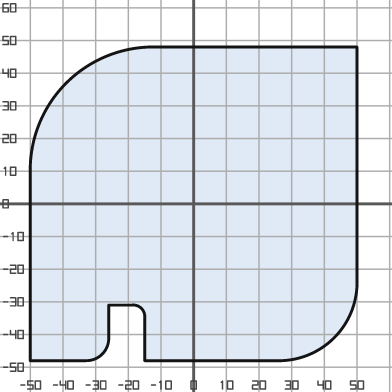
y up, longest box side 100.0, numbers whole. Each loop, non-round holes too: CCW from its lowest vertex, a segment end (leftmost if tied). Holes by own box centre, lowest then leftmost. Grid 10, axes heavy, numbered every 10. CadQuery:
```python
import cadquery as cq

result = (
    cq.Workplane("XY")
    .moveTo(-50.0, -48.0)
    .lineTo(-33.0, -48.0)
    .threePointArc((-28.0, -46.0), (-26.0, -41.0))
    .lineTo(-26.0, -31.0)
    .lineTo(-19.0, -31.0)
    .threePointArc((-16.0, -32.0), (-15.0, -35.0))
    .lineTo(-15.0, -48.0)
    .lineTo(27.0, -48.0)
    .threePointArc((43.0, -41.0), (50.0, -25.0))
    .lineTo(50.0, 48.0)
    .lineTo(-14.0, 48.0)
    .threePointArc((-39.0, 37.0), (-50.0, 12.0))
    .close()
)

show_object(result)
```